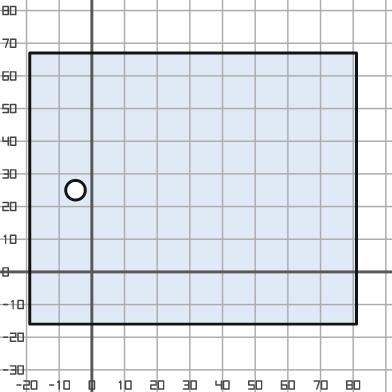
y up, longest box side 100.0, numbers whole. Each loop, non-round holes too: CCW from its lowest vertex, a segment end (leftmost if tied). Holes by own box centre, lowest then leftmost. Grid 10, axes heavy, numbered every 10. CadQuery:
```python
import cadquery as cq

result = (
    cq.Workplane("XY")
    .moveTo(-19.0, -16.0)
    .lineTo(81.0, -16.0)
    .lineTo(81.0, 67.0)
    .lineTo(-19.0, 67.0)
    .close()
    .moveTo(-5.0, 25.0)
    .circle(3.0)
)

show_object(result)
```